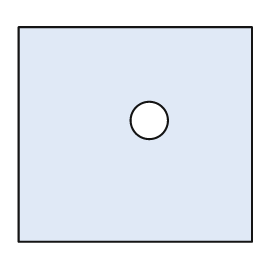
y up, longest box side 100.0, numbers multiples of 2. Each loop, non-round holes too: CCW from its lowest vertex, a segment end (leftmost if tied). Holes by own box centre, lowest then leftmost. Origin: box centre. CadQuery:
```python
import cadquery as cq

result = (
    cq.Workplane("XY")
    .moveTo(-50.0, -46.0)
    .lineTo(50.0, -46.0)
    .lineTo(50.0, 46.0)
    .lineTo(-50.0, 46.0)
    .close()
    .moveTo(6.0, 6.0)
    .circle(8.0)
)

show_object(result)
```